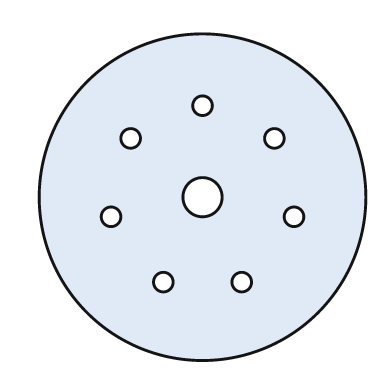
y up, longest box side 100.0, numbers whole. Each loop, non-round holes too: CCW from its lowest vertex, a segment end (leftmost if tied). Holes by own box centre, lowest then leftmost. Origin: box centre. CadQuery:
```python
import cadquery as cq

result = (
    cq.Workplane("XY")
    .moveTo(0.0, 0.0)
    .circle(50.0)
    .moveTo(-12.0, -26.0)
    .circle(3.0)
    .moveTo(12.0, -26.0)
    .circle(3.0)
    .moveTo(-28.0, -6.0)
    .circle(3.0)
    .moveTo(28.0, -6.0)
    .circle(3.0)
    .moveTo(0.0, 0.0)
    .circle(6.0)
    .moveTo(-22.0, 18.0)
    .circle(3.0)
    .moveTo(22.0, 18.0)
    .circle(3.0)
    .moveTo(0.0, 28.0)
    .circle(3.0)
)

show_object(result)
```